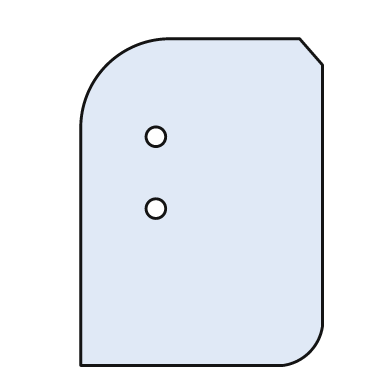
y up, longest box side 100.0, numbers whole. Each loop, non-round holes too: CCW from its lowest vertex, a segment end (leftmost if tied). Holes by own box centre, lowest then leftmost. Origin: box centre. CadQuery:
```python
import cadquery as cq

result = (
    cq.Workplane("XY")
    .moveTo(-37.0, -50.0)
    .lineTo(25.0, -50.0)
    .threePointArc((33.0, -46.0), (37.0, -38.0))
    .lineTo(37.0, 42.0)
    .lineTo(30.0, 50.0)
    .lineTo(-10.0, 50.0)
    .threePointArc((-29.0, 42.0), (-37.0, 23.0))
    .close()
    .moveTo(-14.0, -2.0)
    .circle(3.0)
    .moveTo(-14.0, 20.0)
    .circle(3.0)
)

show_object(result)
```